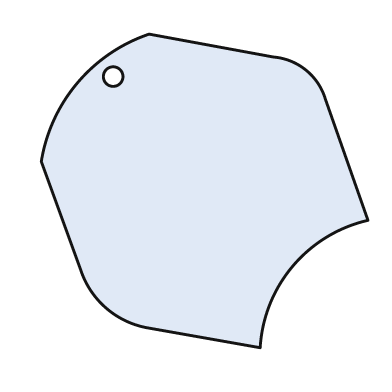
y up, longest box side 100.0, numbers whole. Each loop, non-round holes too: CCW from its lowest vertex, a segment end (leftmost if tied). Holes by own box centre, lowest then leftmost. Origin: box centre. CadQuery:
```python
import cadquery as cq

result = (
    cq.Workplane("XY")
    .moveTo(17.0, -48.0)
    .threePointArc((27.0, -23.0), (50.0, -9.0))
    .lineTo(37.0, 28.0)
    .threePointArc((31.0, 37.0), (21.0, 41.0))
    .lineTo(-17.0, 48.0)
    .threePointArc((-39.0, 33.0), (-50.0, 9.0))
    .lineTo(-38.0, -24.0)
    .threePointArc((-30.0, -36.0), (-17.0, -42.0))
    .close()
    .moveTo(-28.0, 35.0)
    .circle(3.0)
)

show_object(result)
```